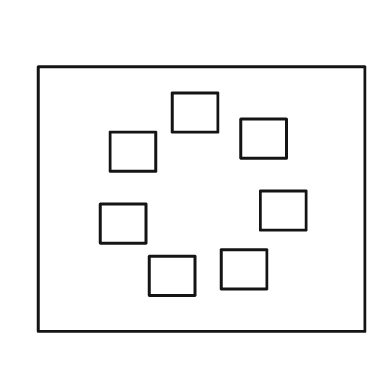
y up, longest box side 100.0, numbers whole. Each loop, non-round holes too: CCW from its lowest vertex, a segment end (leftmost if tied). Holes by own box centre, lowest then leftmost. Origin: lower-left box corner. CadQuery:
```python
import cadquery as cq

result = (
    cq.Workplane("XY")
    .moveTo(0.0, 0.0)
    .lineTo(100.0, 0.0)
    .lineTo(100.0, 81.0)
    .lineTo(0.0, 81.0)
    .close()
    .moveTo(34.0, 11.0)
    .lineTo(48.0, 11.0)
    .lineTo(48.0, 23.0)
    .lineTo(34.0, 23.0)
    .close()
    .moveTo(56.0, 13.0)
    .lineTo(70.0, 13.0)
    .lineTo(70.0, 25.0)
    .lineTo(56.0, 25.0)
    .close()
    .moveTo(19.0, 27.0)
    .lineTo(33.0, 27.0)
    .lineTo(33.0, 39.0)
    .lineTo(19.0, 39.0)
    .close()
    .moveTo(68.0, 31.0)
    .lineTo(82.0, 31.0)
    .lineTo(82.0, 43.0)
    .lineTo(68.0, 43.0)
    .close()
    .moveTo(22.0, 49.0)
    .lineTo(36.0, 49.0)
    .lineTo(36.0, 61.0)
    .lineTo(22.0, 61.0)
    .close()
    .moveTo(62.0, 53.0)
    .lineTo(76.0, 53.0)
    .lineTo(76.0, 65.0)
    .lineTo(62.0, 65.0)
    .close()
    .moveTo(41.0, 61.0)
    .lineTo(55.0, 61.0)
    .lineTo(55.0, 73.0)
    .lineTo(41.0, 73.0)
    .close()
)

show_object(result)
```